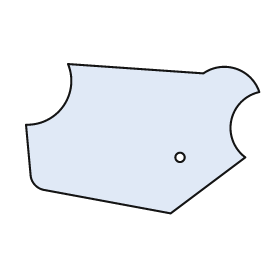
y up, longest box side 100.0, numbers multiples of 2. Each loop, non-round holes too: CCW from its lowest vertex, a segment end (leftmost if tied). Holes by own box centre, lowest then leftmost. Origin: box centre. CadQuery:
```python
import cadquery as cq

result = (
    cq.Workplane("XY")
    .moveTo(12.0, -32.0)
    .lineTo(44.0, -8.0)
    .threePointArc((38.0, 8.0), (50.0, 20.0))
    .threePointArc((40.0, 30.0), (26.0, 28.0))
    .lineTo(-32.0, 32.0)
    .threePointArc((-34.0, 14.0), (-50.0, 6.0))
    .lineTo(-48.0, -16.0)
    .threePointArc((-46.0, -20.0), (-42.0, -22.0))
    .close()
    .moveTo(16.0, -8.0)
    .circle(2.0)
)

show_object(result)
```